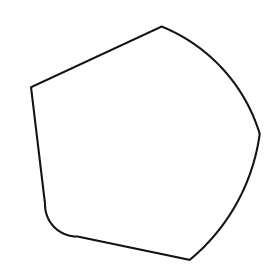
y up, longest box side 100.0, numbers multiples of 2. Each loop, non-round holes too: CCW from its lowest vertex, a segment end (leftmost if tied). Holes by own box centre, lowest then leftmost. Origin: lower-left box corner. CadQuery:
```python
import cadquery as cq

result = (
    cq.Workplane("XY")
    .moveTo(68.0, 0.0)
    .threePointArc((88.0, 24.0), (98.0, 54.0))
    .threePointArc((82.0, 82.0), (56.0, 100.0))
    .lineTo(0.0, 74.0)
    .lineTo(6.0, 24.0)
    .threePointArc((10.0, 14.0), (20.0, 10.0))
    .close()
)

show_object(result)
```